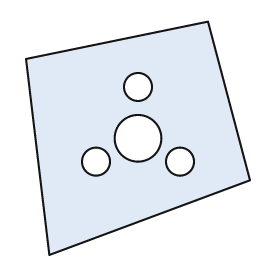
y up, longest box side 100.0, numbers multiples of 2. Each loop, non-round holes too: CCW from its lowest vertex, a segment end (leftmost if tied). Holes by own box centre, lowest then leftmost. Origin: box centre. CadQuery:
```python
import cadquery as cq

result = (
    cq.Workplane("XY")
    .moveTo(-38.0, -50.0)
    .lineTo(48.0, -18.0)
    .lineTo(30.0, 50.0)
    .lineTo(-48.0, 34.0)
    .close()
    .moveTo(-18.0, -10.0)
    .circle(6.0)
    .moveTo(18.0, -10.0)
    .circle(6.0)
    .moveTo(0.0, 0.0)
    .circle(10.0)
    .moveTo(0.0, 22.0)
    .circle(6.0)
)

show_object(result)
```